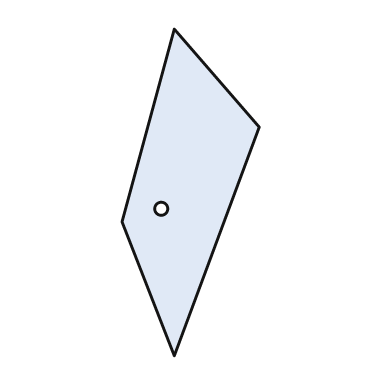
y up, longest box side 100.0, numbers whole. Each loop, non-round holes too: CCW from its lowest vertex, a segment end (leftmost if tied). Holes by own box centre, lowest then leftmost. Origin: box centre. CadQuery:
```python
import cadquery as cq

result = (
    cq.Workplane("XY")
    .moveTo(-5.0, -50.0)
    .lineTo(21.0, 20.0)
    .lineTo(-5.0, 50.0)
    .lineTo(-21.0, -9.0)
    .close()
    .moveTo(-9.0, -5.0)
    .circle(2.0)
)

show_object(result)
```